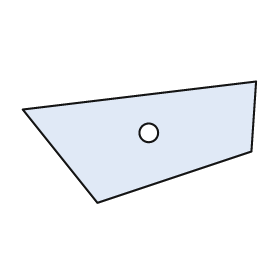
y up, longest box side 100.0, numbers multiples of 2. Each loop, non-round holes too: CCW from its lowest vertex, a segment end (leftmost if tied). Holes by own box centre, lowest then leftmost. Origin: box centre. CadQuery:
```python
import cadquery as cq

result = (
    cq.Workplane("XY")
    .moveTo(-18.0, -26.0)
    .lineTo(48.0, -4.0)
    .lineTo(50.0, 26.0)
    .lineTo(-50.0, 14.0)
    .close()
    .moveTo(4.0, 4.0)
    .circle(4.0)
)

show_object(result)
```